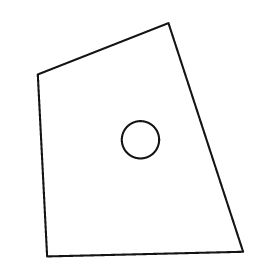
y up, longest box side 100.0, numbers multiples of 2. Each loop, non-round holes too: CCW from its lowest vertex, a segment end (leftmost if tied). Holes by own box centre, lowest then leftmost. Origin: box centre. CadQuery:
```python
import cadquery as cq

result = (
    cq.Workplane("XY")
    .moveTo(-40.0, -50.0)
    .lineTo(44.0, -48.0)
    .lineTo(12.0, 50.0)
    .lineTo(-44.0, 28.0)
    .close()
    .moveTo(0.0, 0.0)
    .circle(8.0)
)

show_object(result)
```